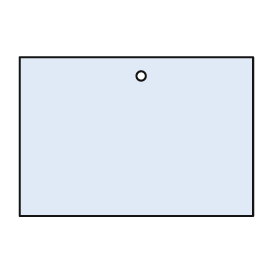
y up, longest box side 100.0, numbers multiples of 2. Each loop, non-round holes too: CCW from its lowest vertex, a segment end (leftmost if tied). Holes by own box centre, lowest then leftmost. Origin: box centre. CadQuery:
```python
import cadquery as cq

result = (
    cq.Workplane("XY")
    .moveTo(-50.0, -34.0)
    .lineTo(50.0, -34.0)
    .lineTo(50.0, 34.0)
    .lineTo(-50.0, 34.0)
    .close()
    .moveTo(2.0, 26.0)
    .circle(2.0)
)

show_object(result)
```